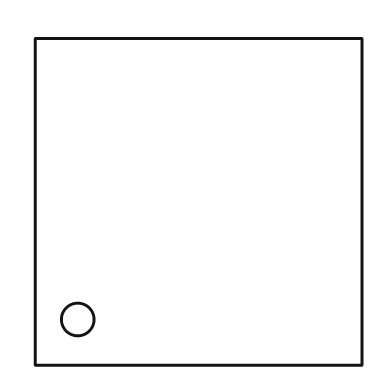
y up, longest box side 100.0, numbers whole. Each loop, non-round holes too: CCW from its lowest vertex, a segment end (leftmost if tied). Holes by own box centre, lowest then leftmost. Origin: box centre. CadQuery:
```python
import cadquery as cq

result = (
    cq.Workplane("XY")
    .moveTo(-50.0, -50.0)
    .lineTo(50.0, -50.0)
    .lineTo(50.0, 50.0)
    .lineTo(-50.0, 50.0)
    .close()
    .moveTo(-37.0, -36.0)
    .circle(5.0)
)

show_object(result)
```